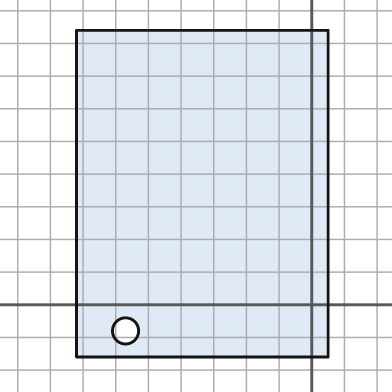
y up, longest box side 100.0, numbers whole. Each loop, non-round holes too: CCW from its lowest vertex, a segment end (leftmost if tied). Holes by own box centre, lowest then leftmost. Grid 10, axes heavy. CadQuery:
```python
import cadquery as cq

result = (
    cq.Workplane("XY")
    .moveTo(-72.0, -16.0)
    .lineTo(5.0, -16.0)
    .lineTo(5.0, 84.0)
    .lineTo(-72.0, 84.0)
    .close()
    .moveTo(-57.0, -8.0)
    .circle(4.0)
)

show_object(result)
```